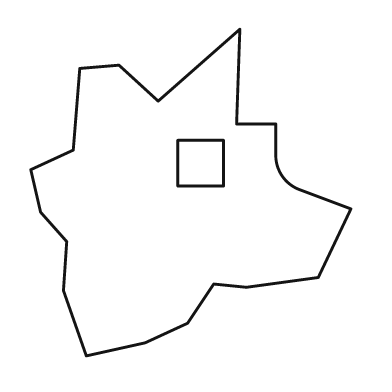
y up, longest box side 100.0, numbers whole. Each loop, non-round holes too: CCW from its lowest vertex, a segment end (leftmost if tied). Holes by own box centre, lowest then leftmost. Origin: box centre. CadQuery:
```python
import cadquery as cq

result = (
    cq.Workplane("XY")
    .moveTo(-32.0, -50.0)
    .lineTo(-14.0, -46.0)
    .lineTo(-1.0, -40.0)
    .lineTo(7.0, -28.0)
    .lineTo(17.0, -29.0)
    .lineTo(39.0, -26.0)
    .lineTo(49.0, -5.0)
    .lineTo(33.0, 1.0)
    .threePointArc((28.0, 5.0), (26.0, 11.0))
    .lineTo(26.0, 21.0)
    .lineTo(14.0, 21.0)
    .lineTo(15.0, 50.0)
    .lineTo(-10.0, 28.0)
    .lineTo(-22.0, 39.0)
    .lineTo(-34.0, 38.0)
    .lineTo(-36.0, 13.0)
    .lineTo(-49.0, 7.0)
    .lineTo(-46.0, -6.0)
    .lineTo(-38.0, -15.0)
    .lineTo(-39.0, -30.0)
    .close()
    .moveTo(-4.0, 2.0)
    .lineTo(10.0, 2.0)
    .lineTo(10.0, 16.0)
    .lineTo(-4.0, 16.0)
    .close()
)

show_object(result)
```